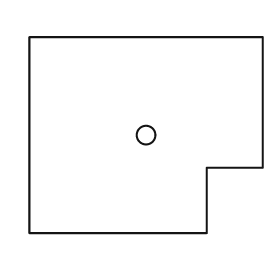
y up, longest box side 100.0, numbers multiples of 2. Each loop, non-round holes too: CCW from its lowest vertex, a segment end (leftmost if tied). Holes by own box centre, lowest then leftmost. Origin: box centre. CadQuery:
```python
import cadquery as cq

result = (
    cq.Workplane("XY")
    .moveTo(-50.0, -42.0)
    .lineTo(26.0, -42.0)
    .lineTo(26.0, -14.0)
    .lineTo(50.0, -14.0)
    .lineTo(50.0, 42.0)
    .lineTo(-50.0, 42.0)
    .close()
    .moveTo(0.0, 0.0)
    .circle(4.0)
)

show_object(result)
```